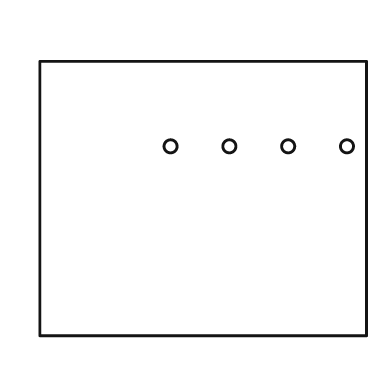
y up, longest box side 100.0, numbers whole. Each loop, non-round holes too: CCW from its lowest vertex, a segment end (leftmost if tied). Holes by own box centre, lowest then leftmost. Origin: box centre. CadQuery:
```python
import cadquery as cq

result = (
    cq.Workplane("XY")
    .moveTo(-50.0, -42.0)
    .lineTo(50.0, -42.0)
    .lineTo(50.0, 42.0)
    .lineTo(-50.0, 42.0)
    .close()
    .moveTo(-10.0, 16.0)
    .circle(2.0)
    .moveTo(8.0, 16.0)
    .circle(2.0)
    .moveTo(26.0, 16.0)
    .circle(2.0)
    .moveTo(44.0, 16.0)
    .circle(2.0)
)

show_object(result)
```